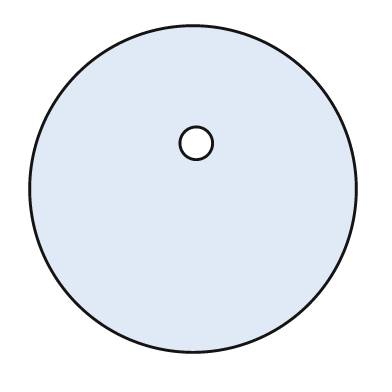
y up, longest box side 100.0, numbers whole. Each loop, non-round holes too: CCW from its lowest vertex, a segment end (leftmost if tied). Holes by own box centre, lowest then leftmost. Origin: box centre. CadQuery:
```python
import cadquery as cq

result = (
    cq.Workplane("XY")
    .moveTo(0.0, 0.0)
    .circle(50.0)
    .moveTo(1.0, 14.0)
    .circle(5.0)
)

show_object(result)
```